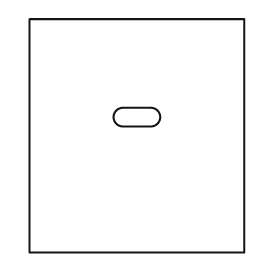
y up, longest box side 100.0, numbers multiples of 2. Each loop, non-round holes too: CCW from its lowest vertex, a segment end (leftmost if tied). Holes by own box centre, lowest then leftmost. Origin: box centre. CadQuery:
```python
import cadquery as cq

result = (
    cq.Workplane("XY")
    .moveTo(-46.0, -50.0)
    .lineTo(46.0, -50.0)
    .lineTo(46.0, 50.0)
    .lineTo(-46.0, 50.0)
    .close()
    .moveTo(-6.0, 4.0)
    .lineTo(6.0, 4.0)
    .threePointArc((10.0, 8.0), (6.0, 12.0))
    .lineTo(-6.0, 12.0)
    .threePointArc((-10.0, 8.0), (-6.0, 4.0))
    .close()
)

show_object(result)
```